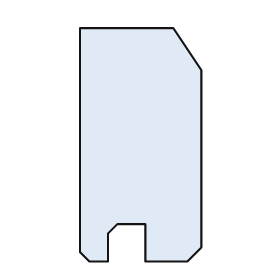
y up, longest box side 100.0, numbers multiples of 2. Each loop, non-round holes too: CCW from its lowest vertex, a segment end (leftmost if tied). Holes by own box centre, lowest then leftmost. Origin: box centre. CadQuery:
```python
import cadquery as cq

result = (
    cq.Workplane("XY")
    .moveTo(-22.0, -50.0)
    .lineTo(-14.0, -50.0)
    .lineTo(-14.0, -38.0)
    .lineTo(-10.0, -34.0)
    .lineTo(2.0, -34.0)
    .lineTo(2.0, -50.0)
    .lineTo(20.0, -50.0)
    .lineTo(26.0, -44.0)
    .lineTo(26.0, 32.0)
    .lineTo(14.0, 50.0)
    .lineTo(-26.0, 50.0)
    .lineTo(-26.0, -46.0)
    .close()
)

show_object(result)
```